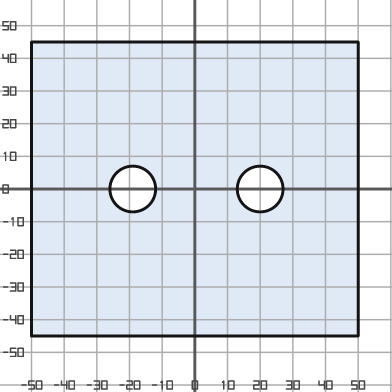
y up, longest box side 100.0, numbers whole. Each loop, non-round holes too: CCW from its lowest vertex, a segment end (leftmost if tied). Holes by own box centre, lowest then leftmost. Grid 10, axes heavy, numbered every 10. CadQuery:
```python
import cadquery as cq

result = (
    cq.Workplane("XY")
    .moveTo(-50.0, -45.0)
    .lineTo(50.0, -45.0)
    .lineTo(50.0, 45.0)
    .lineTo(-50.0, 45.0)
    .close()
    .moveTo(-19.0, 0.0)
    .circle(7.0)
    .moveTo(20.0, 0.0)
    .circle(7.0)
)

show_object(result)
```